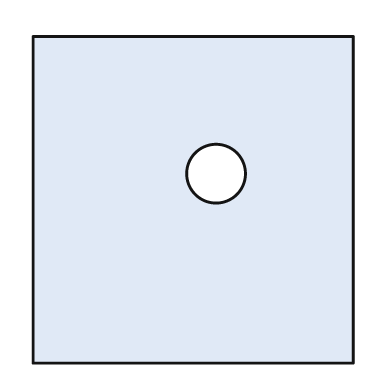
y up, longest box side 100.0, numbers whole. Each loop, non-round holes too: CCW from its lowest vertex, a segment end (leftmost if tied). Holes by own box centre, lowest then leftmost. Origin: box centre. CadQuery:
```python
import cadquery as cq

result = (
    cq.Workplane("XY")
    .moveTo(-49.0, -50.0)
    .lineTo(49.0, -50.0)
    .lineTo(49.0, 50.0)
    .lineTo(-49.0, 50.0)
    .close()
    .moveTo(7.0, 8.0)
    .circle(9.0)
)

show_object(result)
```